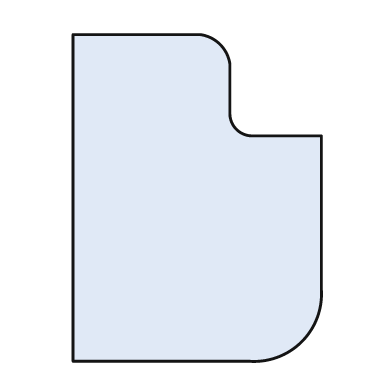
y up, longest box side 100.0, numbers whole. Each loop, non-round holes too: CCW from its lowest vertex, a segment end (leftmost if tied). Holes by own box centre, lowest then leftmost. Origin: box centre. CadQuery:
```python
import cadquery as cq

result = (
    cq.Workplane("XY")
    .moveTo(-38.0, -50.0)
    .lineTo(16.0, -50.0)
    .threePointArc((32.0, -44.0), (38.0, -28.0))
    .lineTo(38.0, 19.0)
    .lineTo(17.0, 19.0)
    .threePointArc((12.0, 21.0), (10.0, 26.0))
    .lineTo(10.0, 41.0)
    .threePointArc((7.0, 47.0), (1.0, 50.0))
    .lineTo(-38.0, 50.0)
    .close()
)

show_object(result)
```